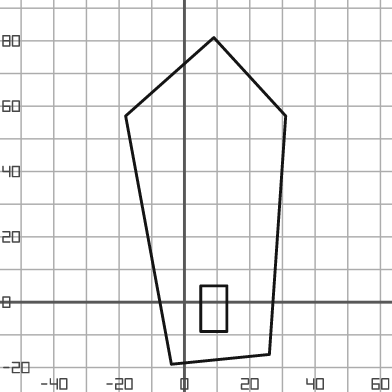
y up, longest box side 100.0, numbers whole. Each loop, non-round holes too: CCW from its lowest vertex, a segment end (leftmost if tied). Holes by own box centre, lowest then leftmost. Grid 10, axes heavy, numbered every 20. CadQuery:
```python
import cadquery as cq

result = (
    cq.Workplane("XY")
    .moveTo(-4.0, -19.0)
    .lineTo(26.0, -16.0)
    .lineTo(31.0, 57.0)
    .lineTo(9.0, 81.0)
    .lineTo(-18.0, 57.0)
    .close()
    .moveTo(5.0, -9.0)
    .lineTo(13.0, -9.0)
    .lineTo(13.0, 5.0)
    .lineTo(5.0, 5.0)
    .close()
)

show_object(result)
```